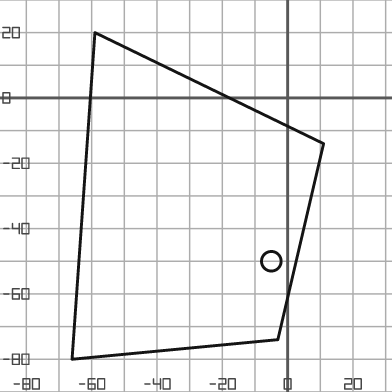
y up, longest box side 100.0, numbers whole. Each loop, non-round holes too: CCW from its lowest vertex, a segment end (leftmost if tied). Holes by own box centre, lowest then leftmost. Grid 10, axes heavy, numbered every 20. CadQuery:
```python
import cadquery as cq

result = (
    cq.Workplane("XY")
    .moveTo(-66.0, -80.0)
    .lineTo(-3.0, -74.0)
    .lineTo(11.0, -14.0)
    .lineTo(-59.0, 20.0)
    .close()
    .moveTo(-5.0, -50.0)
    .circle(3.0)
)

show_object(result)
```